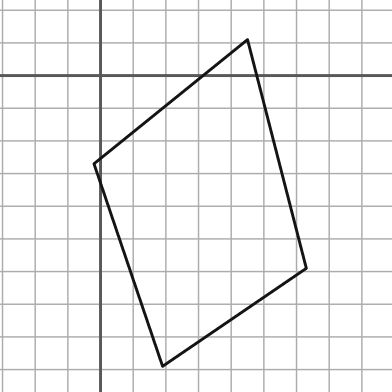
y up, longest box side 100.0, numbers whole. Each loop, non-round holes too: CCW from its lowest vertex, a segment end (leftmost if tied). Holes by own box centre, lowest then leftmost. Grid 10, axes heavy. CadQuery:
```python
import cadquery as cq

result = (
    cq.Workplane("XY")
    .moveTo(19.0, -89.0)
    .lineTo(63.0, -59.0)
    .lineTo(45.0, 11.0)
    .lineTo(-2.0, -27.0)
    .close()
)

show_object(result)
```